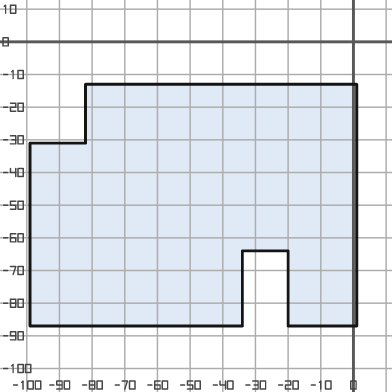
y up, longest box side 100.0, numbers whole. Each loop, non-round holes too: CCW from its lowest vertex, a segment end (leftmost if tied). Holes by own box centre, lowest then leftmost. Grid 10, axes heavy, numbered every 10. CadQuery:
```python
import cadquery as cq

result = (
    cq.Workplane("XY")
    .moveTo(-99.0, -87.0)
    .lineTo(-34.0, -87.0)
    .lineTo(-34.0, -64.0)
    .lineTo(-20.0, -64.0)
    .lineTo(-20.0, -87.0)
    .lineTo(1.0, -87.0)
    .lineTo(1.0, -13.0)
    .lineTo(-82.0, -13.0)
    .lineTo(-82.0, -31.0)
    .lineTo(-99.0, -31.0)
    .close()
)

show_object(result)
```